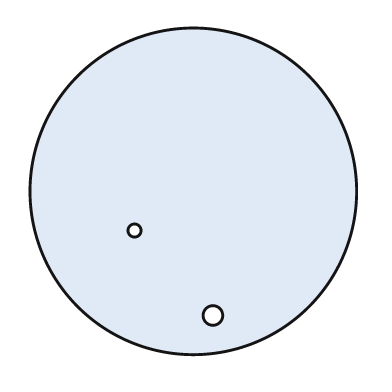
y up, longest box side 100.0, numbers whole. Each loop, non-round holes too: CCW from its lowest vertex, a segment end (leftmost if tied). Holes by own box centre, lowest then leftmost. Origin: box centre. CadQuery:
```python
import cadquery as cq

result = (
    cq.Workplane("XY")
    .moveTo(0.0, 0.0)
    .circle(50.0)
    .moveTo(6.0, -38.0)
    .circle(3.0)
    .moveTo(-18.0, -12.0)
    .circle(2.0)
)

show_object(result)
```